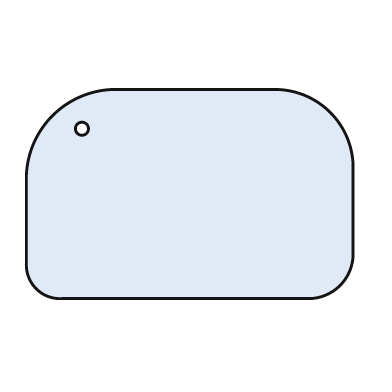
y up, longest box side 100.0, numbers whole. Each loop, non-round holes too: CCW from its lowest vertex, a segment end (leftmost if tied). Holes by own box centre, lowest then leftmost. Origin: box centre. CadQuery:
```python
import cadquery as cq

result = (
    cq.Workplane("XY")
    .moveTo(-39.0, -32.0)
    .lineTo(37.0, -32.0)
    .threePointArc((46.0, -28.0), (50.0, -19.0))
    .lineTo(50.0, 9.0)
    .threePointArc((43.0, 25.0), (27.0, 32.0))
    .lineTo(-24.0, 32.0)
    .threePointArc((-42.0, 24.0), (-50.0, 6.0))
    .lineTo(-50.0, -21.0)
    .threePointArc((-47.0, -29.0), (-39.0, -32.0))
    .close()
    .moveTo(-33.0, 20.0)
    .circle(2.0)
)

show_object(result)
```